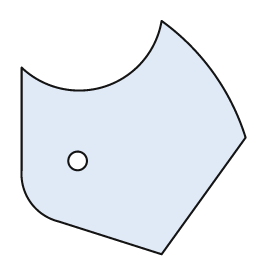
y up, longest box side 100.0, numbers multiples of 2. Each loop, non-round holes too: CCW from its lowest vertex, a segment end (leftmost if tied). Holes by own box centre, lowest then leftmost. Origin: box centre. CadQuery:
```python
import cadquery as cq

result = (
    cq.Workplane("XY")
    .moveTo(12.0, -50.0)
    .lineTo(48.0, 0.0)
    .threePointArc((34.0, 28.0), (12.0, 50.0))
    .threePointArc((-12.0, 22.0), (-48.0, 30.0))
    .lineTo(-48.0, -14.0)
    .threePointArc((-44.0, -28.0), (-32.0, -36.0))
    .close()
    .moveTo(-24.0, -10.0)
    .circle(4.0)
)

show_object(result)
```